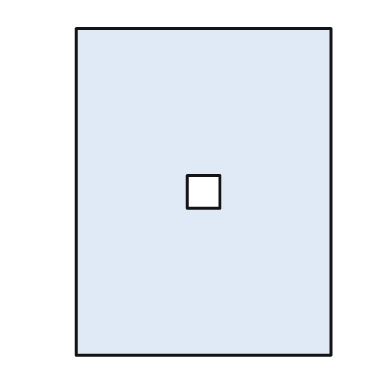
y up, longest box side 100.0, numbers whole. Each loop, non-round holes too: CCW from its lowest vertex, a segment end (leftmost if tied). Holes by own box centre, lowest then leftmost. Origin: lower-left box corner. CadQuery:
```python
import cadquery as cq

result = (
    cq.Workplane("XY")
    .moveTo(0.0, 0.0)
    .lineTo(78.0, 0.0)
    .lineTo(78.0, 100.0)
    .lineTo(0.0, 100.0)
    .close()
    .moveTo(34.0, 45.0)
    .lineTo(44.0, 45.0)
    .lineTo(44.0, 55.0)
    .lineTo(34.0, 55.0)
    .close()
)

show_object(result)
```